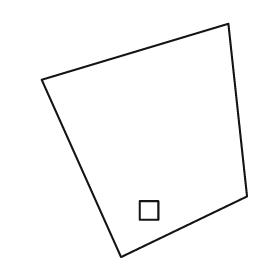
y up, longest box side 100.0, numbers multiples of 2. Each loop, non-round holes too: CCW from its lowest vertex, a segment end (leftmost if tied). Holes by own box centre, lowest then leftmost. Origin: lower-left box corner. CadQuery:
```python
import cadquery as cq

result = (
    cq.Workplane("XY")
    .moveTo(34.0, 0.0)
    .lineTo(88.0, 26.0)
    .lineTo(80.0, 100.0)
    .lineTo(0.0, 76.0)
    .close()
    .moveTo(42.0, 16.0)
    .lineTo(50.0, 16.0)
    .lineTo(50.0, 24.0)
    .lineTo(42.0, 24.0)
    .close()
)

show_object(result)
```